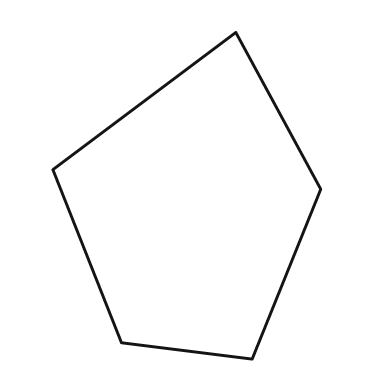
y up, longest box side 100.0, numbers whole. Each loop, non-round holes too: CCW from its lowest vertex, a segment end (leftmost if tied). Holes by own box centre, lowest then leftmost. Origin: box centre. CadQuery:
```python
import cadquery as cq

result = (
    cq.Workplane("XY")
    .moveTo(20.0, -50.0)
    .lineTo(41.0, 2.0)
    .lineTo(15.0, 50.0)
    .lineTo(-41.0, 8.0)
    .lineTo(-20.0, -45.0)
    .close()
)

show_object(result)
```